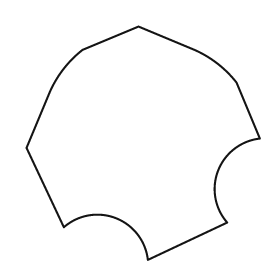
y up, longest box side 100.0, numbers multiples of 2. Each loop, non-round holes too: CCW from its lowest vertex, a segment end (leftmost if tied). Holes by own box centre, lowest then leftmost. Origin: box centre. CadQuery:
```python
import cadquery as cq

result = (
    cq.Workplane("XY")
    .moveTo(2.0, -50.0)
    .lineTo(36.0, -34.0)
    .threePointArc((32.0, -12.0), (50.0, 2.0))
    .lineTo(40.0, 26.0)
    .threePointArc((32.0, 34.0), (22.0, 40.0))
    .lineTo(-2.0, 50.0)
    .lineTo(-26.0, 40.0)
    .threePointArc((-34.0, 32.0), (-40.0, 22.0))
    .lineTo(-50.0, -2.0)
    .lineTo(-34.0, -36.0)
    .threePointArc((-12.0, -32.0), (2.0, -50.0))
    .close()
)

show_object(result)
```